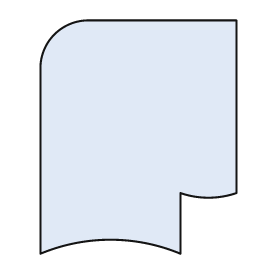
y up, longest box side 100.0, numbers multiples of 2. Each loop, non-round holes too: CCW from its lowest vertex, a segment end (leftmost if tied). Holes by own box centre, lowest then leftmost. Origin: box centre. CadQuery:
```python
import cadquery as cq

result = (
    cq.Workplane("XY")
    .moveTo(-42.0, -50.0)
    .threePointArc((-12.0, -44.0), (18.0, -50.0))
    .lineTo(18.0, -24.0)
    .threePointArc((30.0, -26.0), (42.0, -24.0))
    .lineTo(42.0, 50.0)
    .lineTo(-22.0, 50.0)
    .threePointArc((-36.0, 44.0), (-42.0, 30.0))
    .close()
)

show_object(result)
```